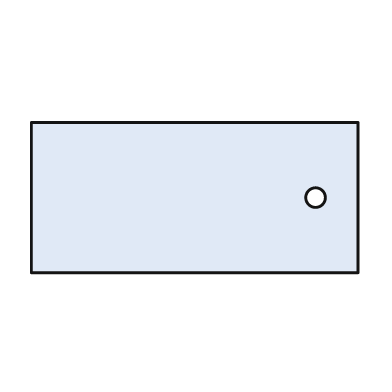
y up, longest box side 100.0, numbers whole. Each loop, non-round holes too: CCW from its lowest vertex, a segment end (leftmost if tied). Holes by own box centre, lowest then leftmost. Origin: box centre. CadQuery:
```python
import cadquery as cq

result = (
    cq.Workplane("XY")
    .moveTo(-50.0, -23.0)
    .lineTo(50.0, -23.0)
    .lineTo(50.0, 23.0)
    .lineTo(-50.0, 23.0)
    .close()
    .moveTo(37.0, 0.0)
    .circle(3.0)
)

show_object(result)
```